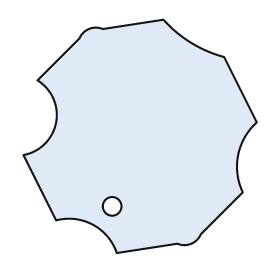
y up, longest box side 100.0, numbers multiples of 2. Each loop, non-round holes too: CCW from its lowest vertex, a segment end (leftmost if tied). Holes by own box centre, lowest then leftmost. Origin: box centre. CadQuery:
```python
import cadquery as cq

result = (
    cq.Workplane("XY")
    .moveTo(-10.0, -50.0)
    .lineTo(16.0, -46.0)
    .threePointArc((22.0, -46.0), (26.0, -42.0))
    .lineTo(44.0, -24.0)
    .threePointArc((42.0, -8.0), (50.0, 6.0))
    .lineTo(36.0, 34.0)
    .threePointArc((22.0, 40.0), (10.0, 50.0))
    .lineTo(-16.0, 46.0)
    .threePointArc((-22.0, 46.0), (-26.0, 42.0))
    .lineTo(-44.0, 24.0)
    .threePointArc((-36.0, 6.0), (-50.0, -8.0))
    .lineTo(-36.0, -36.0)
    .threePointArc((-20.0, -38.0), (-10.0, -50.0))
    .close()
    .moveTo(-12.0, -30.0)
    .circle(4.0)
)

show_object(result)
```